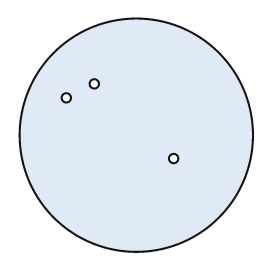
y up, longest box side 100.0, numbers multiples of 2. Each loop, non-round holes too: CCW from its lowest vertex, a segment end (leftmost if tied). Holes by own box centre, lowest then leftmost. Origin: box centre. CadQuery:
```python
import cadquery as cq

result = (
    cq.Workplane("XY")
    .moveTo(0.0, 0.0)
    .circle(50.0)
    .moveTo(16.0, -10.0)
    .circle(2.0)
    .moveTo(-30.0, 16.0)
    .circle(2.0)
    .moveTo(-18.0, 22.0)
    .circle(2.0)
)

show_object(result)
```